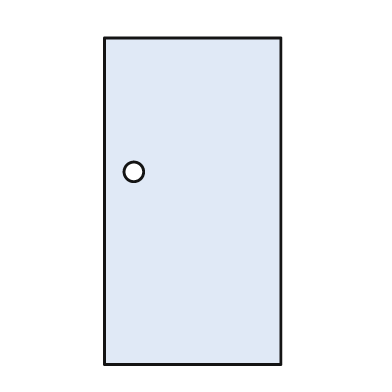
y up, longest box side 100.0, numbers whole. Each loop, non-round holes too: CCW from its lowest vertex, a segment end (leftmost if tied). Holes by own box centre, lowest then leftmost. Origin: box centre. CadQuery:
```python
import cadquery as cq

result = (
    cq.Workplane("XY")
    .moveTo(-27.0, -50.0)
    .lineTo(27.0, -50.0)
    .lineTo(27.0, 50.0)
    .lineTo(-27.0, 50.0)
    .close()
    .moveTo(-18.0, 9.0)
    .circle(3.0)
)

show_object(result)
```